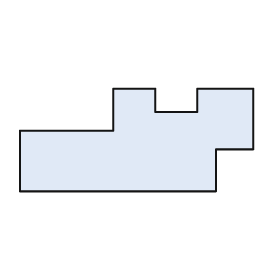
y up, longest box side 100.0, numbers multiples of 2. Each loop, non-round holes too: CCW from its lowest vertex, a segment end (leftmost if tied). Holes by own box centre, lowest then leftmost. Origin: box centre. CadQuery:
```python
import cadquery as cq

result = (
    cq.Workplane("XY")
    .moveTo(-50.0, -22.0)
    .lineTo(34.0, -22.0)
    .lineTo(34.0, -4.0)
    .lineTo(50.0, -4.0)
    .lineTo(50.0, 22.0)
    .lineTo(26.0, 22.0)
    .lineTo(26.0, 12.0)
    .lineTo(8.0, 12.0)
    .lineTo(8.0, 22.0)
    .lineTo(-10.0, 22.0)
    .lineTo(-10.0, 4.0)
    .lineTo(-50.0, 4.0)
    .close()
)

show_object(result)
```